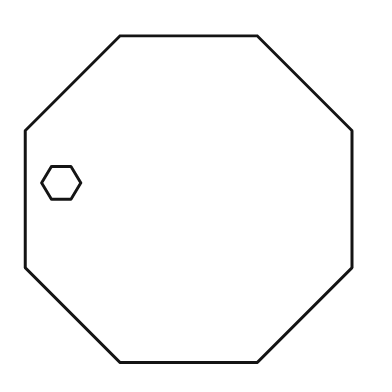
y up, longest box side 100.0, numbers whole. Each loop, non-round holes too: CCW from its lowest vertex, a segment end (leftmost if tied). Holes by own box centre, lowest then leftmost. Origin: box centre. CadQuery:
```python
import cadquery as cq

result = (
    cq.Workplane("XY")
    .moveTo(-21.0, -50.0)
    .lineTo(21.0, -50.0)
    .lineTo(50.0, -21.0)
    .lineTo(50.0, 21.0)
    .lineTo(21.0, 50.0)
    .lineTo(-21.0, 50.0)
    .lineTo(-50.0, 21.0)
    .lineTo(-50.0, -21.0)
    .close()
    .moveTo(-42.0, 0.0)
    .lineTo(-36.0, 0.0)
    .lineTo(-33.0, 5.0)
    .lineTo(-36.0, 10.0)
    .lineTo(-42.0, 10.0)
    .lineTo(-45.0, 5.0)
    .close()
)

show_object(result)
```